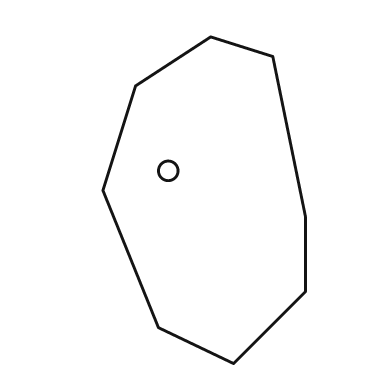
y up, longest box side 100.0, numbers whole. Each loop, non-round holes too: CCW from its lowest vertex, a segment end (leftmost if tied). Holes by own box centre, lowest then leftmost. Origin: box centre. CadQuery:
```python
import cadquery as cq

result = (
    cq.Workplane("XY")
    .moveTo(9.0, -50.0)
    .lineTo(31.0, -28.0)
    .lineTo(31.0, -5.0)
    .lineTo(21.0, 44.0)
    .lineTo(2.0, 50.0)
    .lineTo(-21.0, 35.0)
    .lineTo(-31.0, 3.0)
    .lineTo(-14.0, -39.0)
    .close()
    .moveTo(-11.0, 9.0)
    .circle(3.0)
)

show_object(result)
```